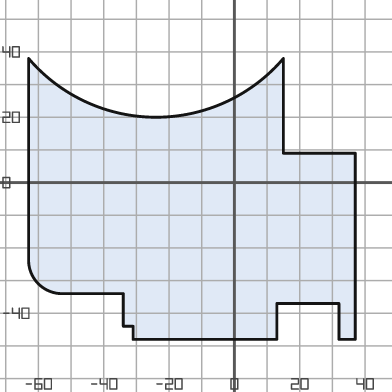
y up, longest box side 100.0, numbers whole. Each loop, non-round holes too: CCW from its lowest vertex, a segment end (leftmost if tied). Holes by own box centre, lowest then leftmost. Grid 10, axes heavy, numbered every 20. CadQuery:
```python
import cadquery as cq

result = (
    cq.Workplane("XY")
    .moveTo(-31.0, -48.0)
    .lineTo(13.0, -48.0)
    .lineTo(13.0, -37.0)
    .lineTo(32.0, -37.0)
    .lineTo(32.0, -48.0)
    .lineTo(37.0, -48.0)
    .lineTo(37.0, 9.0)
    .lineTo(15.0, 9.0)
    .lineTo(15.0, 38.0)
    .threePointArc((-24.0, 20.0), (-63.0, 38.0))
    .lineTo(-63.0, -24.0)
    .threePointArc((-60.0, -31.0), (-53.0, -34.0))
    .lineTo(-34.0, -34.0)
    .lineTo(-34.0, -44.0)
    .lineTo(-31.0, -44.0)
    .close()
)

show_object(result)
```